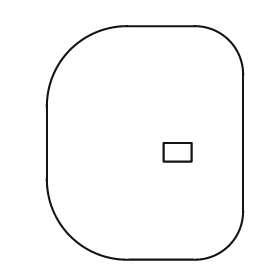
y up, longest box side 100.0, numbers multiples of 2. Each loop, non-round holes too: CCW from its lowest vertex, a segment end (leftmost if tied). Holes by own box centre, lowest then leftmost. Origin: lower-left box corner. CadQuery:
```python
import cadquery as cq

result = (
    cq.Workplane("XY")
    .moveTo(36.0, 0.0)
    .lineTo(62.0, 0.0)
    .threePointArc((78.0, 6.0), (84.0, 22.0))
    .lineTo(84.0, 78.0)
    .threePointArc((78.0, 94.0), (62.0, 100.0))
    .lineTo(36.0, 100.0)
    .threePointArc((10.0, 90.0), (0.0, 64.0))
    .lineTo(0.0, 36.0)
    .threePointArc((10.0, 10.0), (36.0, 0.0))
    .close()
    .moveTo(50.0, 42.0)
    .lineTo(62.0, 42.0)
    .lineTo(62.0, 50.0)
    .lineTo(50.0, 50.0)
    .close()
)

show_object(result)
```